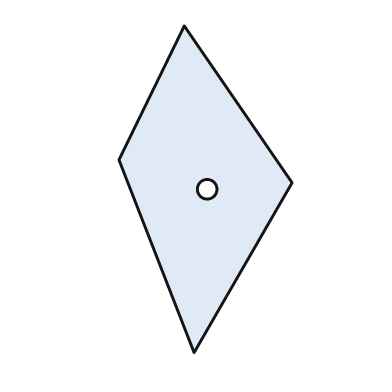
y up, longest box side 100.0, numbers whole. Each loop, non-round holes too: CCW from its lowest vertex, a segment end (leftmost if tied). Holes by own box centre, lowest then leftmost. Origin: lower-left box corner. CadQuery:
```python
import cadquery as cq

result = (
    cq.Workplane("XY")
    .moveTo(23.0, 0.0)
    .lineTo(53.0, 52.0)
    .lineTo(20.0, 100.0)
    .lineTo(0.0, 59.0)
    .close()
    .moveTo(27.0, 50.0)
    .circle(3.0)
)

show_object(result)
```